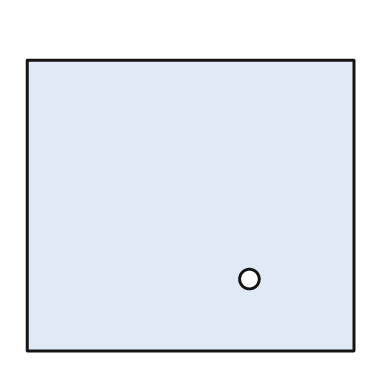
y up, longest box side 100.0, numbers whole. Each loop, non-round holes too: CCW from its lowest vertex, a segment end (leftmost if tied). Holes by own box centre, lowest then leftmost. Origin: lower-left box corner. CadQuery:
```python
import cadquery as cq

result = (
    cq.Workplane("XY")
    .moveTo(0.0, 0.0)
    .lineTo(100.0, 0.0)
    .lineTo(100.0, 89.0)
    .lineTo(0.0, 89.0)
    .close()
    .moveTo(68.0, 22.0)
    .circle(3.0)
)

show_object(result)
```